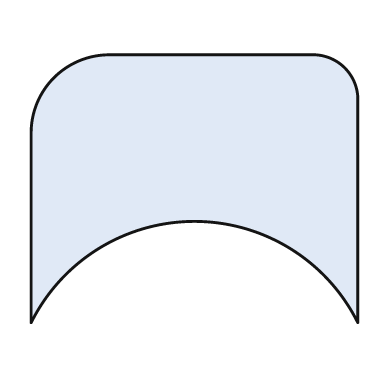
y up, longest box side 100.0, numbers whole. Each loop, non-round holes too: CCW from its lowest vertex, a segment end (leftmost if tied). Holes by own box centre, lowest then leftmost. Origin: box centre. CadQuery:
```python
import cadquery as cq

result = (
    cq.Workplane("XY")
    .moveTo(-50.0, -41.0)
    .threePointArc((0.0, -10.0), (50.0, -41.0))
    .lineTo(50.0, 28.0)
    .threePointArc((46.0, 37.0), (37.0, 41.0))
    .lineTo(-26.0, 41.0)
    .threePointArc((-43.0, 34.0), (-50.0, 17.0))
    .close()
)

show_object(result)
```